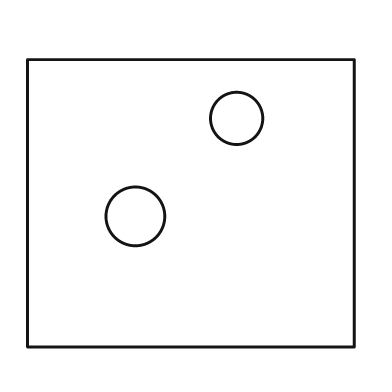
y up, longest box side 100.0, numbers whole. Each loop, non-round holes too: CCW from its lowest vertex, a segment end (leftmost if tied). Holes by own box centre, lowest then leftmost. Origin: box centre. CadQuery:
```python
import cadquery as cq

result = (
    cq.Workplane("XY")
    .moveTo(-50.0, -44.0)
    .lineTo(50.0, -44.0)
    .lineTo(50.0, 44.0)
    .lineTo(-50.0, 44.0)
    .close()
    .moveTo(-17.0, -4.0)
    .circle(9.0)
    .moveTo(14.0, 26.0)
    .circle(8.0)
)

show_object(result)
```